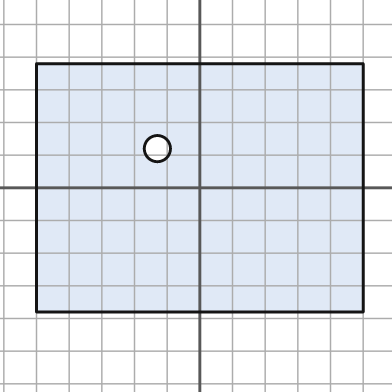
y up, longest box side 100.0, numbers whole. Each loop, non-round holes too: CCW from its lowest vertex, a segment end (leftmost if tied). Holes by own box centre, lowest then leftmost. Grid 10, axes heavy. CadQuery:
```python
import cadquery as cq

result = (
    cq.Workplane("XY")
    .moveTo(-50.0, -38.0)
    .lineTo(50.0, -38.0)
    .lineTo(50.0, 38.0)
    .lineTo(-50.0, 38.0)
    .close()
    .moveTo(-13.0, 12.0)
    .circle(4.0)
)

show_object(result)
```